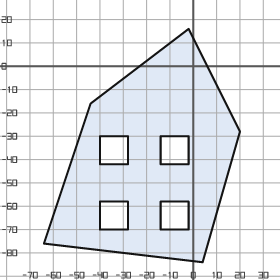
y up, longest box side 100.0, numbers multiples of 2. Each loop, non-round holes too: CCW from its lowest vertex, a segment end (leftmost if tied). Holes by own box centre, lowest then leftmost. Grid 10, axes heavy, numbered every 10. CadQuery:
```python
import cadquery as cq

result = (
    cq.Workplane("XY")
    .moveTo(4.0, -84.0)
    .lineTo(20.0, -28.0)
    .lineTo(-2.0, 16.0)
    .lineTo(-44.0, -16.0)
    .lineTo(-64.0, -76.0)
    .close()
    .moveTo(-40.0, -70.0)
    .lineTo(-28.0, -70.0)
    .lineTo(-28.0, -58.0)
    .lineTo(-40.0, -58.0)
    .close()
    .moveTo(-14.0, -70.0)
    .lineTo(-2.0, -70.0)
    .lineTo(-2.0, -58.0)
    .lineTo(-14.0, -58.0)
    .close()
    .moveTo(-40.0, -42.0)
    .lineTo(-28.0, -42.0)
    .lineTo(-28.0, -30.0)
    .lineTo(-40.0, -30.0)
    .close()
    .moveTo(-14.0, -42.0)
    .lineTo(-2.0, -42.0)
    .lineTo(-2.0, -30.0)
    .lineTo(-14.0, -30.0)
    .close()
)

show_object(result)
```